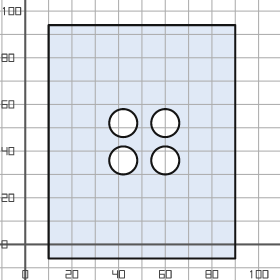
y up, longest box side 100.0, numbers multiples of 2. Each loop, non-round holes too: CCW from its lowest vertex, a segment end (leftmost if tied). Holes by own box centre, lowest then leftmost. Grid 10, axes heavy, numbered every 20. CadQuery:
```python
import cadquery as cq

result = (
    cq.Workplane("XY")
    .moveTo(10.0, -6.0)
    .lineTo(90.0, -6.0)
    .lineTo(90.0, 94.0)
    .lineTo(10.0, 94.0)
    .close()
    .moveTo(42.0, 36.0)
    .circle(6.0)
    .moveTo(60.0, 36.0)
    .circle(6.0)
    .moveTo(42.0, 52.0)
    .circle(6.0)
    .moveTo(60.0, 52.0)
    .circle(6.0)
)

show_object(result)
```